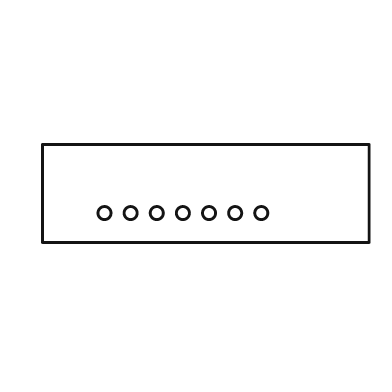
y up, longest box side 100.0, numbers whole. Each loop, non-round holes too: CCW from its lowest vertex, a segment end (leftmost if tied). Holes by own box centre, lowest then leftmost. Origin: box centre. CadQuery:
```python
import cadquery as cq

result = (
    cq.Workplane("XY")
    .moveTo(-50.0, -15.0)
    .lineTo(50.0, -15.0)
    .lineTo(50.0, 15.0)
    .lineTo(-50.0, 15.0)
    .close()
    .moveTo(-31.0, -6.0)
    .circle(2.0)
    .moveTo(-23.0, -6.0)
    .circle(2.0)
    .moveTo(-15.0, -6.0)
    .circle(2.0)
    .moveTo(-7.0, -6.0)
    .circle(2.0)
    .moveTo(1.0, -6.0)
    .circle(2.0)
    .moveTo(9.0, -6.0)
    .circle(2.0)
    .moveTo(17.0, -6.0)
    .circle(2.0)
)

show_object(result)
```